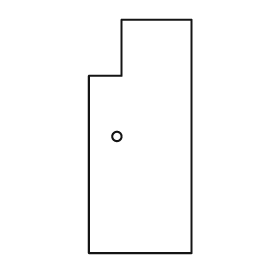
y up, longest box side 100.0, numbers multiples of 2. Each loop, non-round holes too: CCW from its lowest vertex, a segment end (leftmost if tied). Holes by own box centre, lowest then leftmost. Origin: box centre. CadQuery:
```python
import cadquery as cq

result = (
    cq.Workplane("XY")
    .moveTo(-22.0, -50.0)
    .lineTo(22.0, -50.0)
    .lineTo(22.0, 50.0)
    .lineTo(-8.0, 50.0)
    .lineTo(-8.0, 26.0)
    .lineTo(-22.0, 26.0)
    .close()
    .moveTo(-10.0, 0.0)
    .circle(2.0)
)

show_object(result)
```